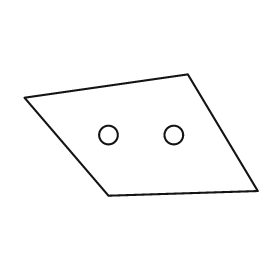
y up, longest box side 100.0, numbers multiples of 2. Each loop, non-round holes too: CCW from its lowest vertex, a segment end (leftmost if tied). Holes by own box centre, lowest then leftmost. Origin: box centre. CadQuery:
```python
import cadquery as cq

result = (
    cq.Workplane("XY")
    .moveTo(-14.0, -26.0)
    .lineTo(50.0, -24.0)
    .lineTo(20.0, 26.0)
    .lineTo(-50.0, 16.0)
    .close()
    .moveTo(-14.0, 0.0)
    .circle(4.0)
    .moveTo(14.0, 0.0)
    .circle(4.0)
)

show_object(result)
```